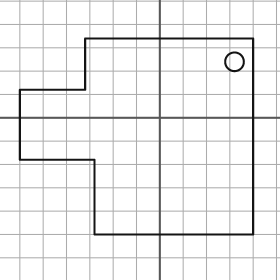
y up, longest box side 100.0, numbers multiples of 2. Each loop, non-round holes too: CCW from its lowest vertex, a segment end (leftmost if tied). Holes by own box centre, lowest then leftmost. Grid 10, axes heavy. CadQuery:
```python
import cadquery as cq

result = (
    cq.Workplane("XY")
    .moveTo(-28.0, -50.0)
    .lineTo(40.0, -50.0)
    .lineTo(40.0, 34.0)
    .lineTo(-32.0, 34.0)
    .lineTo(-32.0, 12.0)
    .lineTo(-60.0, 12.0)
    .lineTo(-60.0, -18.0)
    .lineTo(-28.0, -18.0)
    .close()
    .moveTo(32.0, 24.0)
    .circle(4.0)
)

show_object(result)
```